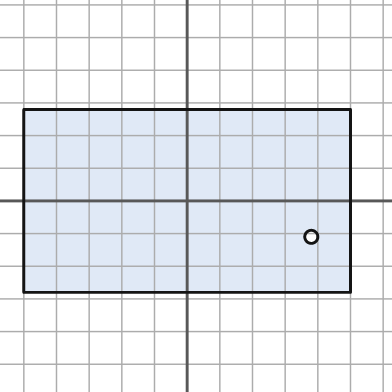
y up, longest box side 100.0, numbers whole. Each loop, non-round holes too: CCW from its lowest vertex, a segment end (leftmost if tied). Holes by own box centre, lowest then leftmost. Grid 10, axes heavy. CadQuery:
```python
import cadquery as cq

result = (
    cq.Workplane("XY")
    .moveTo(-50.0, -28.0)
    .lineTo(50.0, -28.0)
    .lineTo(50.0, 28.0)
    .lineTo(-50.0, 28.0)
    .close()
    .moveTo(38.0, -11.0)
    .circle(2.0)
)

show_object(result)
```